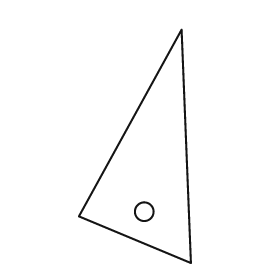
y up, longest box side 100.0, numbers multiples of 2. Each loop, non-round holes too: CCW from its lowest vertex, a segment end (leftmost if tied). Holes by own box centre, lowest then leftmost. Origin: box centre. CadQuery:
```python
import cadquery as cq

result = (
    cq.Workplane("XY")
    .moveTo(24.0, -50.0)
    .lineTo(20.0, 50.0)
    .lineTo(-24.0, -30.0)
    .close()
    .moveTo(4.0, -28.0)
    .circle(4.0)
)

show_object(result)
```